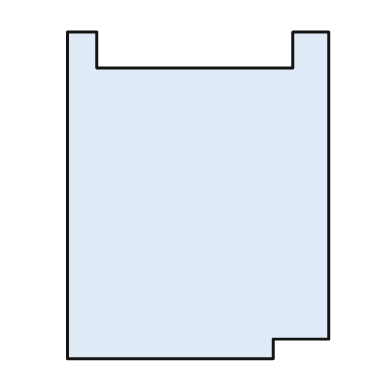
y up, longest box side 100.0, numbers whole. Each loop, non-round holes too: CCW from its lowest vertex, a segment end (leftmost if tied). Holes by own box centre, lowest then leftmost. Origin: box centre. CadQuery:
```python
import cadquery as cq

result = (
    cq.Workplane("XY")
    .moveTo(-40.0, -50.0)
    .lineTo(23.0, -50.0)
    .lineTo(23.0, -44.0)
    .lineTo(40.0, -44.0)
    .lineTo(40.0, 50.0)
    .lineTo(29.0, 50.0)
    .lineTo(29.0, 39.0)
    .lineTo(-31.0, 39.0)
    .lineTo(-31.0, 50.0)
    .lineTo(-40.0, 50.0)
    .close()
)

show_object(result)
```